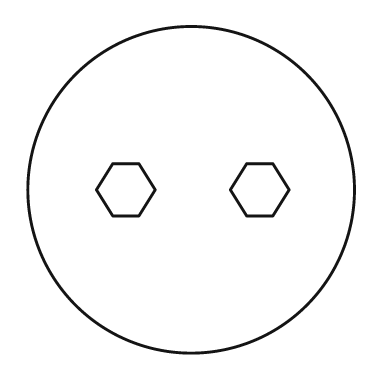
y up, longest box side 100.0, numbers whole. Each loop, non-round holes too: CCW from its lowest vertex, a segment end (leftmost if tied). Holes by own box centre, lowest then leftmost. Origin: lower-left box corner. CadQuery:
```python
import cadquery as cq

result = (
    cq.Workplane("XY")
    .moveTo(50.0, 50.0)
    .circle(50.0)
    .moveTo(26.0, 42.0)
    .lineTo(34.0, 42.0)
    .lineTo(39.0, 50.0)
    .lineTo(34.0, 58.0)
    .lineTo(26.0, 58.0)
    .lineTo(21.0, 50.0)
    .close()
    .moveTo(67.0, 42.0)
    .lineTo(75.0, 42.0)
    .lineTo(80.0, 50.0)
    .lineTo(75.0, 58.0)
    .lineTo(67.0, 58.0)
    .lineTo(62.0, 50.0)
    .close()
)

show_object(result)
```